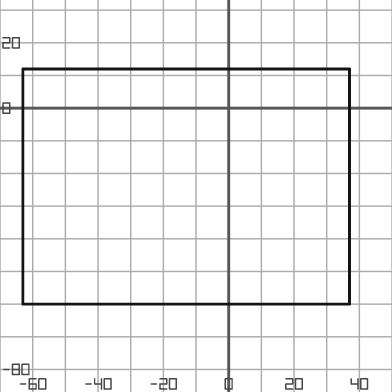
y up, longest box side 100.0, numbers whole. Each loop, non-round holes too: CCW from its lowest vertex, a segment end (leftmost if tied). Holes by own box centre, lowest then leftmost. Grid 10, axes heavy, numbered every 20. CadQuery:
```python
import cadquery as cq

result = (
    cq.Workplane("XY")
    .moveTo(-63.0, -60.0)
    .lineTo(37.0, -60.0)
    .lineTo(37.0, 12.0)
    .lineTo(-63.0, 12.0)
    .close()
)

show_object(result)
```